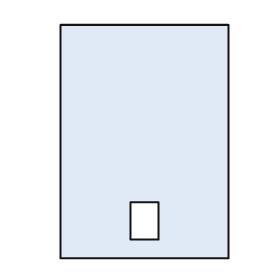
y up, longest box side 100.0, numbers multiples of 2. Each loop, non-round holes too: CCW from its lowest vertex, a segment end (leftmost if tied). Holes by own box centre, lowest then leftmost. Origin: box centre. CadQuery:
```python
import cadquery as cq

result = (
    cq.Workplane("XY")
    .moveTo(-36.0, -50.0)
    .lineTo(36.0, -50.0)
    .lineTo(36.0, 50.0)
    .lineTo(-36.0, 50.0)
    .close()
    .moveTo(-6.0, -42.0)
    .lineTo(6.0, -42.0)
    .lineTo(6.0, -26.0)
    .lineTo(-6.0, -26.0)
    .close()
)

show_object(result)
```